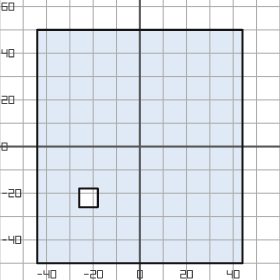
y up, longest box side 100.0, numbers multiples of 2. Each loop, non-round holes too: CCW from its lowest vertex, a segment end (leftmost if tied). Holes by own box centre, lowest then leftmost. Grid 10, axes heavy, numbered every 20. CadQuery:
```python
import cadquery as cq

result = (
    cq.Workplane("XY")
    .moveTo(-44.0, -50.0)
    .lineTo(44.0, -50.0)
    .lineTo(44.0, 50.0)
    .lineTo(-44.0, 50.0)
    .close()
    .moveTo(-26.0, -26.0)
    .lineTo(-18.0, -26.0)
    .lineTo(-18.0, -18.0)
    .lineTo(-26.0, -18.0)
    .close()
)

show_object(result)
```